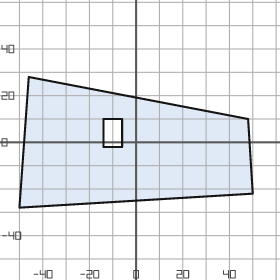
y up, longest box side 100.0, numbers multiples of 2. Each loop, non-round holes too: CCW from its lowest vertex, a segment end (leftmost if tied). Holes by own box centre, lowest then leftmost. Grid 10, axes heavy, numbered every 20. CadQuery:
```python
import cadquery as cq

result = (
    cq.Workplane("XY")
    .moveTo(-50.0, -28.0)
    .lineTo(50.0, -22.0)
    .lineTo(48.0, 10.0)
    .lineTo(-46.0, 28.0)
    .close()
    .moveTo(-14.0, -2.0)
    .lineTo(-6.0, -2.0)
    .lineTo(-6.0, 10.0)
    .lineTo(-14.0, 10.0)
    .close()
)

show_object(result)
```